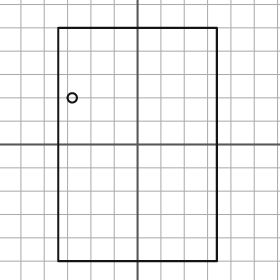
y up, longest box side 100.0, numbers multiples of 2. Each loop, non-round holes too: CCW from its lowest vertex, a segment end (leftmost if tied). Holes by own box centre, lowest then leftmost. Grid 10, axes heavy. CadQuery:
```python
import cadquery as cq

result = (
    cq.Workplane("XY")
    .moveTo(-34.0, -50.0)
    .lineTo(34.0, -50.0)
    .lineTo(34.0, 50.0)
    .lineTo(-34.0, 50.0)
    .close()
    .moveTo(-28.0, 20.0)
    .circle(2.0)
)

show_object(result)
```